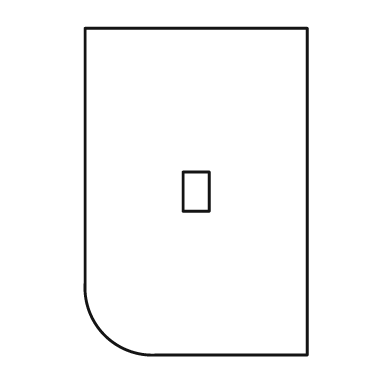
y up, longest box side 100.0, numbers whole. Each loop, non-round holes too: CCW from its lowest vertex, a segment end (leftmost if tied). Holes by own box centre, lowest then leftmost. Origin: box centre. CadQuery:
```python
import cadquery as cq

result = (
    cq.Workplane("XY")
    .moveTo(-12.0, -50.0)
    .lineTo(34.0, -50.0)
    .lineTo(34.0, 50.0)
    .lineTo(-34.0, 50.0)
    .lineTo(-34.0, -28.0)
    .threePointArc((-28.0, -44.0), (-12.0, -50.0))
    .close()
    .moveTo(-4.0, -6.0)
    .lineTo(4.0, -6.0)
    .lineTo(4.0, 6.0)
    .lineTo(-4.0, 6.0)
    .close()
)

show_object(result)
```